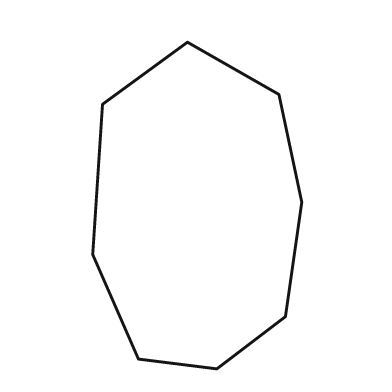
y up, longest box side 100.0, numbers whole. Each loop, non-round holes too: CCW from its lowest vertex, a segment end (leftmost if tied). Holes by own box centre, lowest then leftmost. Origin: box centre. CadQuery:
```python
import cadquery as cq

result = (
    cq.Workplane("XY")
    .moveTo(6.0, -50.0)
    .lineTo(27.0, -34.0)
    .lineTo(32.0, 1.0)
    .lineTo(25.0, 34.0)
    .lineTo(-3.0, 50.0)
    .lineTo(-29.0, 31.0)
    .lineTo(-32.0, -15.0)
    .lineTo(-18.0, -47.0)
    .close()
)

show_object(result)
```